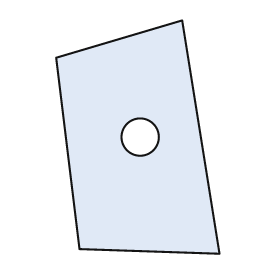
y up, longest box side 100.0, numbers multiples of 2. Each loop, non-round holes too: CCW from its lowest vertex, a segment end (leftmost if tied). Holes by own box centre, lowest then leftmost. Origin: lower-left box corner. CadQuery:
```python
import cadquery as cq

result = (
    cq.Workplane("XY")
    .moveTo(70.0, 0.0)
    .lineTo(54.0, 100.0)
    .lineTo(0.0, 84.0)
    .lineTo(10.0, 2.0)
    .close()
    .moveTo(36.0, 50.0)
    .circle(8.0)
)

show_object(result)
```